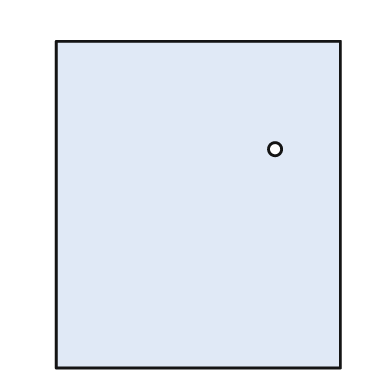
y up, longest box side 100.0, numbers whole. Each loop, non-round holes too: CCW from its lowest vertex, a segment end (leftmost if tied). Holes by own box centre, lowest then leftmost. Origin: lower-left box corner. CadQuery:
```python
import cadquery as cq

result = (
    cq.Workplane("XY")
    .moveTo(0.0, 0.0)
    .lineTo(87.0, 0.0)
    .lineTo(87.0, 100.0)
    .lineTo(0.0, 100.0)
    .close()
    .moveTo(67.0, 67.0)
    .circle(2.0)
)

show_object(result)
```